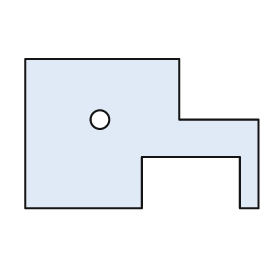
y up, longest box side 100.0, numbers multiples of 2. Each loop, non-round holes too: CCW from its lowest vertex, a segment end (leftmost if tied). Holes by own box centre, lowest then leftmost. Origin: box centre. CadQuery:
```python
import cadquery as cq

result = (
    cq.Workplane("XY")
    .moveTo(-50.0, -32.0)
    .lineTo(0.0, -32.0)
    .lineTo(0.0, -10.0)
    .lineTo(42.0, -10.0)
    .lineTo(42.0, -32.0)
    .lineTo(50.0, -32.0)
    .lineTo(50.0, 6.0)
    .lineTo(16.0, 6.0)
    .lineTo(16.0, 32.0)
    .lineTo(-50.0, 32.0)
    .close()
    .moveTo(-18.0, 6.0)
    .circle(4.0)
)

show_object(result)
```